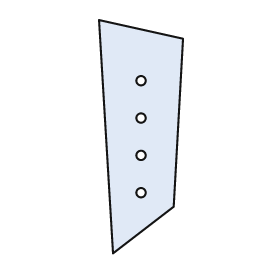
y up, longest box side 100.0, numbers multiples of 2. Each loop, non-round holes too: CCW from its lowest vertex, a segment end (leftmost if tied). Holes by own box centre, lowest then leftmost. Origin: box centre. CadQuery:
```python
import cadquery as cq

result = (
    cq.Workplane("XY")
    .moveTo(-12.0, -50.0)
    .lineTo(14.0, -30.0)
    .lineTo(18.0, 42.0)
    .lineTo(-18.0, 50.0)
    .close()
    .moveTo(0.0, -24.0)
    .circle(2.0)
    .moveTo(0.0, -8.0)
    .circle(2.0)
    .moveTo(0.0, 8.0)
    .circle(2.0)
    .moveTo(0.0, 24.0)
    .circle(2.0)
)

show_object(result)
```